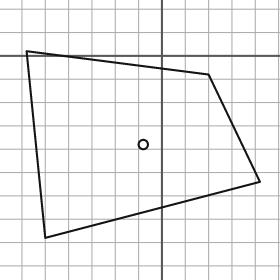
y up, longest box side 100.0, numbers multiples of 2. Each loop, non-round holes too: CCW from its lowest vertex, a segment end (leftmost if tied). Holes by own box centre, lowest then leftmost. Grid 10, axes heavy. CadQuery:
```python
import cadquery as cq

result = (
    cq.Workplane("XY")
    .moveTo(-50.0, -78.0)
    .lineTo(42.0, -54.0)
    .lineTo(20.0, -8.0)
    .lineTo(-58.0, 2.0)
    .close()
    .moveTo(-8.0, -38.0)
    .circle(2.0)
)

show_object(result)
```